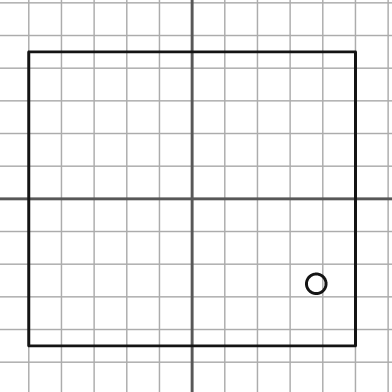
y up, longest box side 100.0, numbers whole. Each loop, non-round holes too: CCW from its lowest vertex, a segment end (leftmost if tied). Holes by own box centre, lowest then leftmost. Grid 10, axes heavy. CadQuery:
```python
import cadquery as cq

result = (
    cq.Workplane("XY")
    .moveTo(-50.0, -45.0)
    .lineTo(50.0, -45.0)
    .lineTo(50.0, 45.0)
    .lineTo(-50.0, 45.0)
    .close()
    .moveTo(38.0, -26.0)
    .circle(3.0)
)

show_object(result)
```